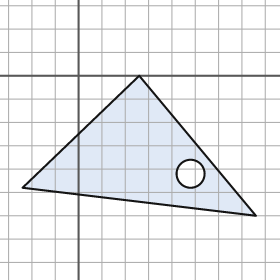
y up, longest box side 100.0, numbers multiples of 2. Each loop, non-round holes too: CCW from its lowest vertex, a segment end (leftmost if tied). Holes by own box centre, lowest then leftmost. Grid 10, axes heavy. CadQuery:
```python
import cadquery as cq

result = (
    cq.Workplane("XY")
    .moveTo(76.0, -60.0)
    .lineTo(26.0, 0.0)
    .lineTo(-24.0, -48.0)
    .close()
    .moveTo(48.0, -42.0)
    .circle(6.0)
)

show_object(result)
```